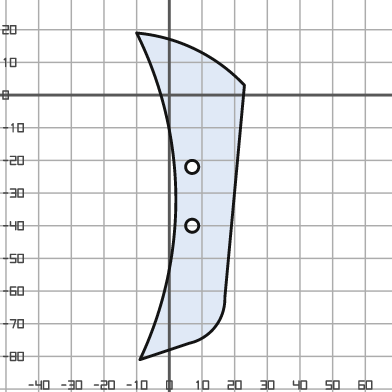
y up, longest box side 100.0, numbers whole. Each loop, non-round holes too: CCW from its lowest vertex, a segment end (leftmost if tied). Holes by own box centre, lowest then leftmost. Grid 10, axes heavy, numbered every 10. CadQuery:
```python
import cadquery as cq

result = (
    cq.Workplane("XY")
    .moveTo(-9.0, -81.0)
    .lineTo(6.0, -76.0)
    .threePointArc((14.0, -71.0), (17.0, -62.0))
    .lineTo(23.0, 3.0)
    .threePointArc((8.0, 14.0), (-10.0, 19.0))
    .threePointArc((2.0, -31.0), (-9.0, -81.0))
    .close()
    .moveTo(7.0, -40.0)
    .circle(2.0)
    .moveTo(7.0, -22.0)
    .circle(2.0)
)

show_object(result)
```